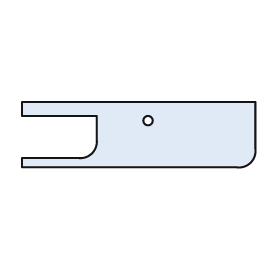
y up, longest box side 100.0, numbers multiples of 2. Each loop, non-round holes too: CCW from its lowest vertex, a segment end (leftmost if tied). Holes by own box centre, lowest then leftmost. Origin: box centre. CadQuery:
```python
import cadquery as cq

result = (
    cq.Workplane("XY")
    .moveTo(-50.0, -14.0)
    .lineTo(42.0, -14.0)
    .threePointArc((48.0, -12.0), (50.0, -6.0))
    .lineTo(50.0, 14.0)
    .lineTo(-50.0, 14.0)
    .lineTo(-50.0, 8.0)
    .lineTo(-18.0, 8.0)
    .lineTo(-18.0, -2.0)
    .threePointArc((-20.0, -8.0), (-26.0, -10.0))
    .lineTo(-50.0, -10.0)
    .close()
    .moveTo(4.0, 6.0)
    .circle(2.0)
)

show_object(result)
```